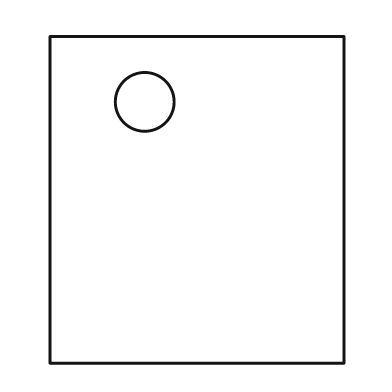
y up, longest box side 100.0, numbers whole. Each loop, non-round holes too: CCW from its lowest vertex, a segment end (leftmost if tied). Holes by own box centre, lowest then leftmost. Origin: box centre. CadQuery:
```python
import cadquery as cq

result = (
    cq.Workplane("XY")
    .moveTo(-45.0, -50.0)
    .lineTo(45.0, -50.0)
    .lineTo(45.0, 50.0)
    .lineTo(-45.0, 50.0)
    .close()
    .moveTo(-16.0, 30.0)
    .circle(9.0)
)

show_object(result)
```